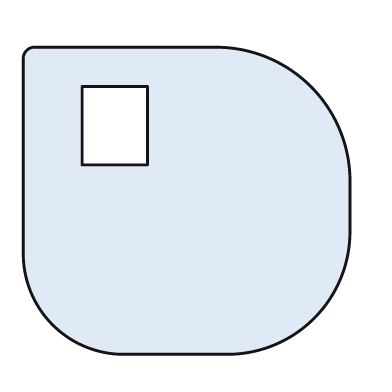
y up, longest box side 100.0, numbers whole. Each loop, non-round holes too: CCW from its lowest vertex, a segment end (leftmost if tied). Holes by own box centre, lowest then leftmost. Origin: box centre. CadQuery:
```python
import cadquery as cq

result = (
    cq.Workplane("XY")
    .moveTo(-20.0, -47.0)
    .lineTo(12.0, -47.0)
    .threePointArc((39.0, -36.0), (50.0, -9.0))
    .lineTo(50.0, 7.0)
    .threePointArc((38.0, 35.0), (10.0, 47.0))
    .lineTo(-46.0, 47.0)
    .threePointArc((-49.0, 46.0), (-50.0, 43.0))
    .lineTo(-50.0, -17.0)
    .threePointArc((-41.0, -38.0), (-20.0, -47.0))
    .close()
    .moveTo(-32.0, 11.0)
    .lineTo(-12.0, 11.0)
    .lineTo(-12.0, 35.0)
    .lineTo(-32.0, 35.0)
    .close()
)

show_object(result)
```